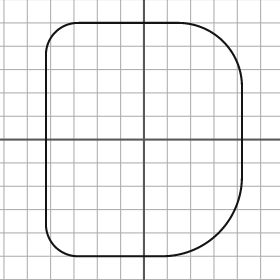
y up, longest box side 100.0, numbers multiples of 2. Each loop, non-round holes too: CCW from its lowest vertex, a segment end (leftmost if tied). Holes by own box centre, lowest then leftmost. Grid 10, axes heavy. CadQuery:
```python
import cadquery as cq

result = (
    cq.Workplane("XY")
    .moveTo(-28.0, -50.0)
    .lineTo(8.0, -50.0)
    .threePointArc((32.0, -40.0), (42.0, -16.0))
    .lineTo(42.0, 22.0)
    .threePointArc((34.0, 42.0), (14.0, 50.0))
    .lineTo(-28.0, 50.0)
    .threePointArc((-38.0, 46.0), (-42.0, 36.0))
    .lineTo(-42.0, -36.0)
    .threePointArc((-38.0, -46.0), (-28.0, -50.0))
    .close()
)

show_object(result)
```